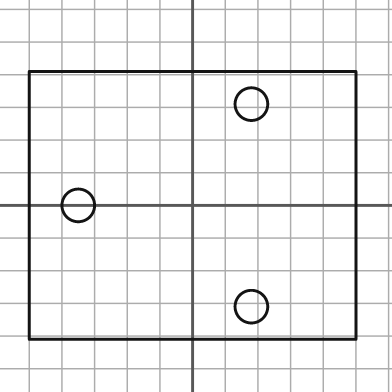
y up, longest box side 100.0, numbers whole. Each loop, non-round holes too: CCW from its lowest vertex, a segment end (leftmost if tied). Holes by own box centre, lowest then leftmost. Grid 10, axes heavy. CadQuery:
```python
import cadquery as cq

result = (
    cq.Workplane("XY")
    .moveTo(-50.0, -41.0)
    .lineTo(50.0, -41.0)
    .lineTo(50.0, 41.0)
    .lineTo(-50.0, 41.0)
    .close()
    .moveTo(18.0, -31.0)
    .circle(5.0)
    .moveTo(-35.0, 0.0)
    .circle(5.0)
    .moveTo(18.0, 31.0)
    .circle(5.0)
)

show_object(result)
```